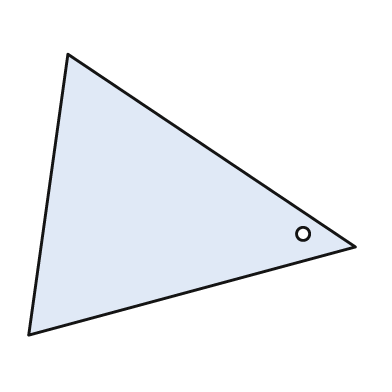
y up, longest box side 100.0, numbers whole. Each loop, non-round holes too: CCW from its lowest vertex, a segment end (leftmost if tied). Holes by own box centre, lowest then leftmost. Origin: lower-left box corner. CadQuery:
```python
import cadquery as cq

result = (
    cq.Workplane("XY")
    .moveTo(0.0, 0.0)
    .lineTo(100.0, 27.0)
    .lineTo(12.0, 86.0)
    .close()
    .moveTo(84.0, 31.0)
    .circle(2.0)
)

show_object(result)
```